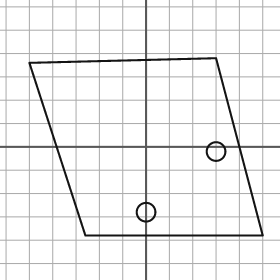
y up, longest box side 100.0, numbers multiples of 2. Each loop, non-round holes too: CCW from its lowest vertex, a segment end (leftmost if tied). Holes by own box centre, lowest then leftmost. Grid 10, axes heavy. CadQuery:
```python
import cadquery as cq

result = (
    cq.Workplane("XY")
    .moveTo(-26.0, -38.0)
    .lineTo(50.0, -38.0)
    .lineTo(30.0, 38.0)
    .lineTo(-50.0, 36.0)
    .close()
    .moveTo(0.0, -28.0)
    .circle(4.0)
    .moveTo(30.0, -2.0)
    .circle(4.0)
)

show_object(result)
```